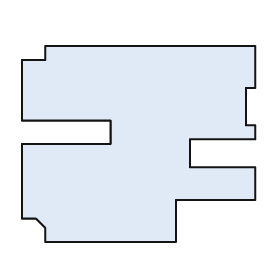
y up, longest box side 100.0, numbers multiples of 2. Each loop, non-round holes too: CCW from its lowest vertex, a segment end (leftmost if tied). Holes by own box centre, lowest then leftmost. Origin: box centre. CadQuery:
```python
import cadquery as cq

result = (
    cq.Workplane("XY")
    .moveTo(-40.0, -42.0)
    .lineTo(16.0, -42.0)
    .lineTo(16.0, -24.0)
    .lineTo(50.0, -24.0)
    .lineTo(50.0, -10.0)
    .lineTo(22.0, -10.0)
    .lineTo(22.0, 2.0)
    .lineTo(50.0, 2.0)
    .lineTo(50.0, 8.0)
    .lineTo(46.0, 8.0)
    .lineTo(46.0, 24.0)
    .lineTo(50.0, 24.0)
    .lineTo(50.0, 42.0)
    .lineTo(-40.0, 42.0)
    .lineTo(-40.0, 36.0)
    .lineTo(-50.0, 36.0)
    .lineTo(-50.0, 10.0)
    .lineTo(-12.0, 10.0)
    .lineTo(-12.0, 0.0)
    .lineTo(-50.0, 0.0)
    .lineTo(-50.0, -32.0)
    .lineTo(-44.0, -32.0)
    .lineTo(-40.0, -36.0)
    .close()
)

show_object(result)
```